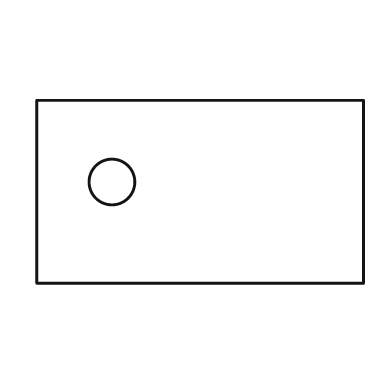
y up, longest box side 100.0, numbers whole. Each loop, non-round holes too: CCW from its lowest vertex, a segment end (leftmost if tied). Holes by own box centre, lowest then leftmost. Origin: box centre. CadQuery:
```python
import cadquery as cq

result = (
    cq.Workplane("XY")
    .moveTo(-50.0, -28.0)
    .lineTo(50.0, -28.0)
    .lineTo(50.0, 28.0)
    .lineTo(-50.0, 28.0)
    .close()
    .moveTo(-27.0, 3.0)
    .circle(7.0)
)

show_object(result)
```